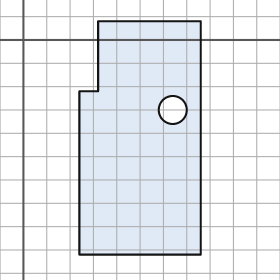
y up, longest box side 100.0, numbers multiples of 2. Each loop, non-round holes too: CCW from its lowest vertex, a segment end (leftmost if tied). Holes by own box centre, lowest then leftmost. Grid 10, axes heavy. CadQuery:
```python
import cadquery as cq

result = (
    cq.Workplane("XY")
    .moveTo(24.0, -92.0)
    .lineTo(76.0, -92.0)
    .lineTo(76.0, 8.0)
    .lineTo(32.0, 8.0)
    .lineTo(32.0, -22.0)
    .lineTo(24.0, -22.0)
    .close()
    .moveTo(64.0, -30.0)
    .circle(6.0)
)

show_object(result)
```